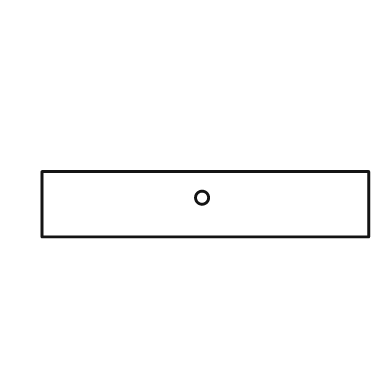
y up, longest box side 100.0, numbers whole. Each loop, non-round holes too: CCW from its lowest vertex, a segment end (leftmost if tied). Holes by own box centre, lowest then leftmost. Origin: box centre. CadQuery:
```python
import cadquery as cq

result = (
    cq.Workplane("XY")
    .moveTo(-50.0, -10.0)
    .lineTo(50.0, -10.0)
    .lineTo(50.0, 10.0)
    .lineTo(-50.0, 10.0)
    .close()
    .moveTo(-1.0, 2.0)
    .circle(2.0)
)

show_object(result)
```